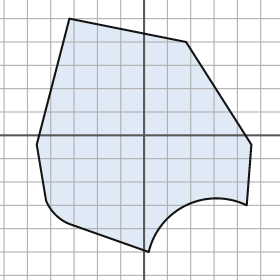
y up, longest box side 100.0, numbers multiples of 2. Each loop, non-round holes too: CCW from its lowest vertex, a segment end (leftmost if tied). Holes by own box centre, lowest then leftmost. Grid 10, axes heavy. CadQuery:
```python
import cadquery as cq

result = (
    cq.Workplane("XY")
    .moveTo(2.0, -50.0)
    .threePointArc((18.0, -30.0), (44.0, -30.0))
    .lineTo(46.0, -4.0)
    .lineTo(18.0, 40.0)
    .lineTo(-32.0, 50.0)
    .lineTo(-46.0, -4.0)
    .lineTo(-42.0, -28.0)
    .threePointArc((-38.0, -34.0), (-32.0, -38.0))
    .close()
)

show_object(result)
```